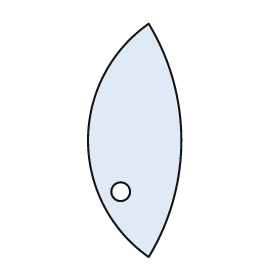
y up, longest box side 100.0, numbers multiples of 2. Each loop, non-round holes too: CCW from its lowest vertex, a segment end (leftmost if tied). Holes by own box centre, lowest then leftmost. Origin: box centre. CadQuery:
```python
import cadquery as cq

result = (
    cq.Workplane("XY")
    .moveTo(6.0, -50.0)
    .threePointArc((20.0, 0.0), (6.0, 50.0))
    .threePointArc((-20.0, 0.0), (6.0, -50.0))
    .close()
    .moveTo(-6.0, -22.0)
    .circle(4.0)
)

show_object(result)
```